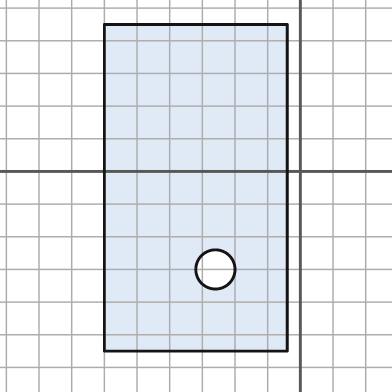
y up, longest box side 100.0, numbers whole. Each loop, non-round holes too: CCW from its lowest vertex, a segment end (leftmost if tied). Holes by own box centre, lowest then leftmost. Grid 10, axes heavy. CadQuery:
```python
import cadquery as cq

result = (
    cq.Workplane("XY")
    .moveTo(-60.0, -55.0)
    .lineTo(-4.0, -55.0)
    .lineTo(-4.0, 45.0)
    .lineTo(-60.0, 45.0)
    .close()
    .moveTo(-26.0, -30.0)
    .circle(6.0)
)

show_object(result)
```